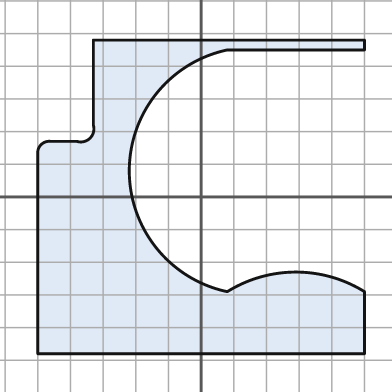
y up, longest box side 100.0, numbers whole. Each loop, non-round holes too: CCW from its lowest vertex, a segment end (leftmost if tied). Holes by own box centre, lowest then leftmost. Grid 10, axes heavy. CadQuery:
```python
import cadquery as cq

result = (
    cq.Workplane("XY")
    .moveTo(-50.0, -48.0)
    .lineTo(50.0, -48.0)
    .lineTo(50.0, -29.0)
    .threePointArc((29.0, -23.0), (8.0, -29.0))
    .threePointArc((-22.0, 8.0), (8.0, 45.0))
    .lineTo(50.0, 45.0)
    .lineTo(50.0, 48.0)
    .lineTo(-33.0, 48.0)
    .lineTo(-33.0, 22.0)
    .threePointArc((-34.0, 18.0), (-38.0, 17.0))
    .lineTo(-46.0, 17.0)
    .threePointArc((-49.0, 16.0), (-50.0, 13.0))
    .close()
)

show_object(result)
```